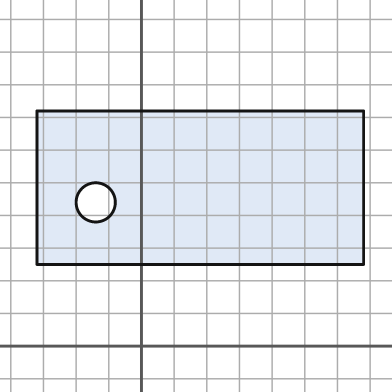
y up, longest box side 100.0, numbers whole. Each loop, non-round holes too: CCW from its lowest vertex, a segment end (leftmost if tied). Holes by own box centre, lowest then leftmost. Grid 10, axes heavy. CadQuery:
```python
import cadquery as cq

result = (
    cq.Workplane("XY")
    .moveTo(-32.0, 25.0)
    .lineTo(68.0, 25.0)
    .lineTo(68.0, 72.0)
    .lineTo(-32.0, 72.0)
    .close()
    .moveTo(-14.0, 44.0)
    .circle(6.0)
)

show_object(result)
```